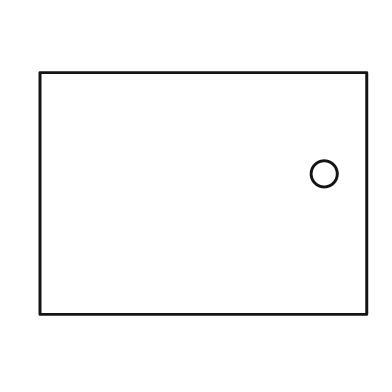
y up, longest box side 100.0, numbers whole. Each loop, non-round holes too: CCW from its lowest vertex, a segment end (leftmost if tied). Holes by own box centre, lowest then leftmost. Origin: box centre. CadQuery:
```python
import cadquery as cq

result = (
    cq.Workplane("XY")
    .moveTo(-50.0, -37.0)
    .lineTo(50.0, -37.0)
    .lineTo(50.0, 37.0)
    .lineTo(-50.0, 37.0)
    .close()
    .moveTo(37.0, 6.0)
    .circle(4.0)
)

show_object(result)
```